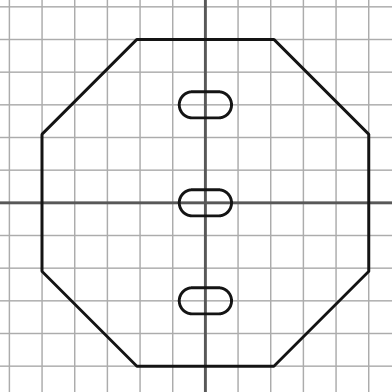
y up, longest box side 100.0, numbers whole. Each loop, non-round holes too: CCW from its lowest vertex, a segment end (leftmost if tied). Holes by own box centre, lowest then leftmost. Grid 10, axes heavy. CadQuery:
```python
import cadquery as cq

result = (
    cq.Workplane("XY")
    .moveTo(-21.0, -50.0)
    .lineTo(21.0, -50.0)
    .lineTo(50.0, -21.0)
    .lineTo(50.0, 21.0)
    .lineTo(21.0, 50.0)
    .lineTo(-21.0, 50.0)
    .lineTo(-50.0, 21.0)
    .lineTo(-50.0, -21.0)
    .close()
    .moveTo(-4.0, -34.0)
    .lineTo(4.0, -34.0)
    .threePointArc((8.0, -30.0), (4.0, -26.0))
    .lineTo(-4.0, -26.0)
    .threePointArc((-8.0, -30.0), (-4.0, -34.0))
    .close()
    .moveTo(-4.0, -4.0)
    .lineTo(4.0, -4.0)
    .threePointArc((8.0, 0.0), (4.0, 4.0))
    .lineTo(-4.0, 4.0)
    .threePointArc((-8.0, 0.0), (-4.0, -4.0))
    .close()
    .moveTo(-4.0, 26.0)
    .lineTo(4.0, 26.0)
    .threePointArc((8.0, 30.0), (4.0, 34.0))
    .lineTo(-4.0, 34.0)
    .threePointArc((-8.0, 30.0), (-4.0, 26.0))
    .close()
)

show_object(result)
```